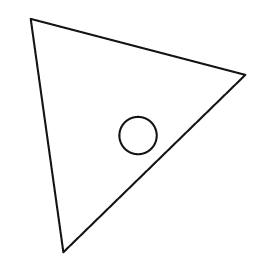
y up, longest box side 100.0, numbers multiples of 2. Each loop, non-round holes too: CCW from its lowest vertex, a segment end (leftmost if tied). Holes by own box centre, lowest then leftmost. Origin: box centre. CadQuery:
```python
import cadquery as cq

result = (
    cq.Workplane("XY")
    .moveTo(-32.0, -50.0)
    .lineTo(46.0, 26.0)
    .lineTo(-46.0, 50.0)
    .close()
    .moveTo(0.0, 0.0)
    .circle(8.0)
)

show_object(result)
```